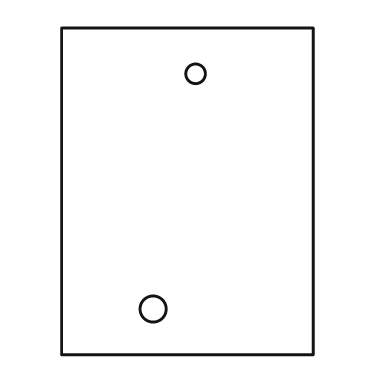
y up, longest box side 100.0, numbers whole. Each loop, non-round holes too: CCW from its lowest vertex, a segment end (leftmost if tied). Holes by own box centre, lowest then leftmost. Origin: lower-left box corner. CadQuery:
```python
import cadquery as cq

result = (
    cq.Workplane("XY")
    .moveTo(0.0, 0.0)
    .lineTo(77.0, 0.0)
    .lineTo(77.0, 100.0)
    .lineTo(0.0, 100.0)
    .close()
    .moveTo(28.0, 14.0)
    .circle(4.0)
    .moveTo(41.0, 86.0)
    .circle(3.0)
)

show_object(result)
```